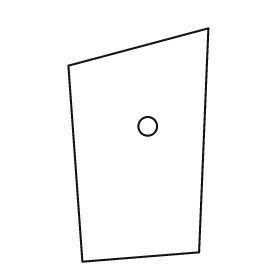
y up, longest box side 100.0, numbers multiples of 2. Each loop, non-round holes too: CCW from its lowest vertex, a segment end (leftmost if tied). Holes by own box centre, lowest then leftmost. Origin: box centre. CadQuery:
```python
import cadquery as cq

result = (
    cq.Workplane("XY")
    .moveTo(-24.0, -50.0)
    .lineTo(26.0, -46.0)
    .lineTo(30.0, 50.0)
    .lineTo(-30.0, 34.0)
    .close()
    .moveTo(4.0, 8.0)
    .circle(4.0)
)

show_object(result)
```